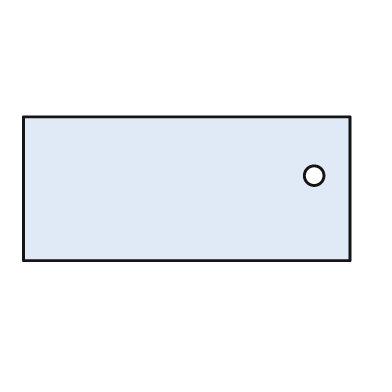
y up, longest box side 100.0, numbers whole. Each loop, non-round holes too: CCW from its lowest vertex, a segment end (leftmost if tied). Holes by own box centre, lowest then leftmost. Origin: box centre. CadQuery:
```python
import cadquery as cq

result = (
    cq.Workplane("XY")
    .moveTo(-50.0, -22.0)
    .lineTo(50.0, -22.0)
    .lineTo(50.0, 22.0)
    .lineTo(-50.0, 22.0)
    .close()
    .moveTo(39.0, 4.0)
    .circle(3.0)
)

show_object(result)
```